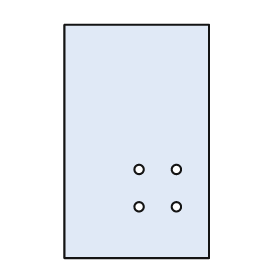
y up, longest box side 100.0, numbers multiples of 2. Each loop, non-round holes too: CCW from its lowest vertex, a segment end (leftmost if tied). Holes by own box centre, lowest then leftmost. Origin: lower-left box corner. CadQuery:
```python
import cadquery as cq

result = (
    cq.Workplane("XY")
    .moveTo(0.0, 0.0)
    .lineTo(62.0, 0.0)
    .lineTo(62.0, 100.0)
    .lineTo(0.0, 100.0)
    .close()
    .moveTo(32.0, 22.0)
    .circle(2.0)
    .moveTo(48.0, 22.0)
    .circle(2.0)
    .moveTo(32.0, 38.0)
    .circle(2.0)
    .moveTo(48.0, 38.0)
    .circle(2.0)
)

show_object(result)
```